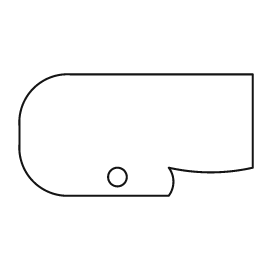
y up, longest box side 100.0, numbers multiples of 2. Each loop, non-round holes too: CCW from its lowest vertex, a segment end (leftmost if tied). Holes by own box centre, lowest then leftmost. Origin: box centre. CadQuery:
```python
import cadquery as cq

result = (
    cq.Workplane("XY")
    .moveTo(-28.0, -26.0)
    .lineTo(14.0, -26.0)
    .threePointArc((16.0, -20.0), (14.0, -14.0))
    .threePointArc((32.0, -16.0), (50.0, -14.0))
    .lineTo(50.0, 26.0)
    .lineTo(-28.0, 26.0)
    .threePointArc((-44.0, 20.0), (-50.0, 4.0))
    .lineTo(-50.0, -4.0)
    .threePointArc((-44.0, -20.0), (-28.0, -26.0))
    .close()
    .moveTo(-8.0, -18.0)
    .circle(4.0)
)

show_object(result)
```